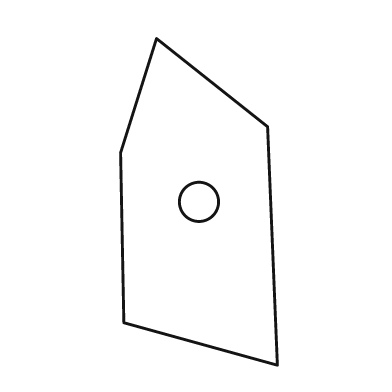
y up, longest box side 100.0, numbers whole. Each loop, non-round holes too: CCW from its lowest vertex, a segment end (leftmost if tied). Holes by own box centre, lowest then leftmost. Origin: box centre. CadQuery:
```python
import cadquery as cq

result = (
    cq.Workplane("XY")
    .moveTo(24.0, -50.0)
    .lineTo(21.0, 23.0)
    .lineTo(-13.0, 50.0)
    .lineTo(-24.0, 15.0)
    .lineTo(-23.0, -37.0)
    .close()
    .moveTo(0.0, 0.0)
    .circle(6.0)
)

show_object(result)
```